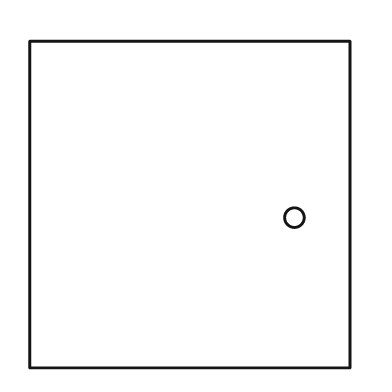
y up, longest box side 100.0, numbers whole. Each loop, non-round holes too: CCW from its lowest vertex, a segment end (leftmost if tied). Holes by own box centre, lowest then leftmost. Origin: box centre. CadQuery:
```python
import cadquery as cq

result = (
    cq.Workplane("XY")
    .moveTo(-49.0, -50.0)
    .lineTo(49.0, -50.0)
    .lineTo(49.0, 50.0)
    .lineTo(-49.0, 50.0)
    .close()
    .moveTo(32.0, -4.0)
    .circle(3.0)
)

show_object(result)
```